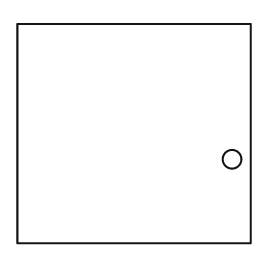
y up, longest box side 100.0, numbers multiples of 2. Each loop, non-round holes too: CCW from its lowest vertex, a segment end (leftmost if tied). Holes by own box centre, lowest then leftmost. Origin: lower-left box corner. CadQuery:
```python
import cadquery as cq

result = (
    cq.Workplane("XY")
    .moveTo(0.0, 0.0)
    .lineTo(100.0, 0.0)
    .lineTo(100.0, 94.0)
    .lineTo(0.0, 94.0)
    .close()
    .moveTo(92.0, 36.0)
    .circle(4.0)
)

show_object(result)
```